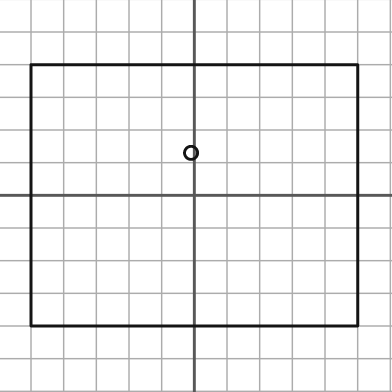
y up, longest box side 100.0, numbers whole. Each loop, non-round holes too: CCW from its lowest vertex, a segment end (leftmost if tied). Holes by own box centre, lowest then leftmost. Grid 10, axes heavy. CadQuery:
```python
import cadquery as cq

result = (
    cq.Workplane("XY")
    .moveTo(-50.0, -40.0)
    .lineTo(50.0, -40.0)
    .lineTo(50.0, 40.0)
    .lineTo(-50.0, 40.0)
    .close()
    .moveTo(-1.0, 13.0)
    .circle(2.0)
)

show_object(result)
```